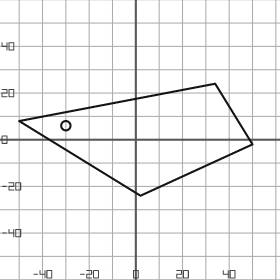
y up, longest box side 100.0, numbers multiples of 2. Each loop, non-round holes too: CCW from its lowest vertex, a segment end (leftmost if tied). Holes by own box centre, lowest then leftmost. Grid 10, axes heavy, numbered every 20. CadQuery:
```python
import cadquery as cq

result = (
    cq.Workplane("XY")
    .moveTo(2.0, -24.0)
    .lineTo(50.0, -2.0)
    .lineTo(34.0, 24.0)
    .lineTo(-50.0, 8.0)
    .close()
    .moveTo(-30.0, 6.0)
    .circle(2.0)
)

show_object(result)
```